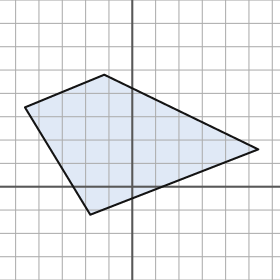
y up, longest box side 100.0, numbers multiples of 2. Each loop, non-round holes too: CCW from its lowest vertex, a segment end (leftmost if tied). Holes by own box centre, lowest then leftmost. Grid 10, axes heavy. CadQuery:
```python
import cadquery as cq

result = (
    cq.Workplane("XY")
    .moveTo(-18.0, -12.0)
    .lineTo(54.0, 16.0)
    .lineTo(-12.0, 48.0)
    .lineTo(-46.0, 34.0)
    .close()
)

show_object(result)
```